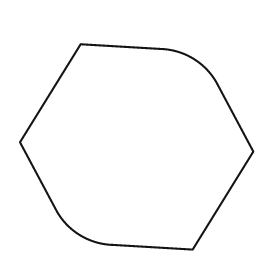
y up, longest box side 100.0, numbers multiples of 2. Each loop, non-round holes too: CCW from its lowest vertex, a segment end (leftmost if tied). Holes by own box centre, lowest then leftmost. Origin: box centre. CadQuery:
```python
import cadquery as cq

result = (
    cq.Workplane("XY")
    .moveTo(24.0, -44.0)
    .lineTo(50.0, -2.0)
    .lineTo(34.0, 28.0)
    .threePointArc((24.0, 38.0), (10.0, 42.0))
    .lineTo(-24.0, 44.0)
    .lineTo(-50.0, 2.0)
    .lineTo(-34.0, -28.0)
    .threePointArc((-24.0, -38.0), (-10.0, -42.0))
    .close()
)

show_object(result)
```